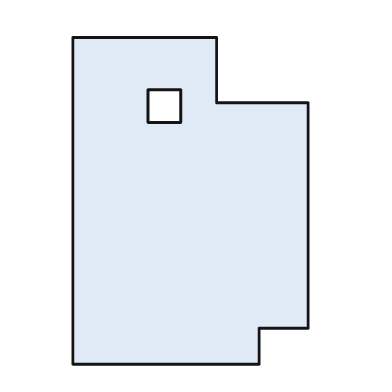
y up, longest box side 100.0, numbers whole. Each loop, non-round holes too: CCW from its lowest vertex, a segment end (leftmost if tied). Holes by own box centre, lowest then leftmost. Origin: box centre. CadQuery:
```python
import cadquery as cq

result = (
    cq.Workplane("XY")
    .moveTo(-36.0, -50.0)
    .lineTo(21.0, -50.0)
    .lineTo(21.0, -39.0)
    .lineTo(36.0, -39.0)
    .lineTo(36.0, 30.0)
    .lineTo(8.0, 30.0)
    .lineTo(8.0, 50.0)
    .lineTo(-36.0, 50.0)
    .close()
    .moveTo(-13.0, 24.0)
    .lineTo(-3.0, 24.0)
    .lineTo(-3.0, 34.0)
    .lineTo(-13.0, 34.0)
    .close()
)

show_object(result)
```